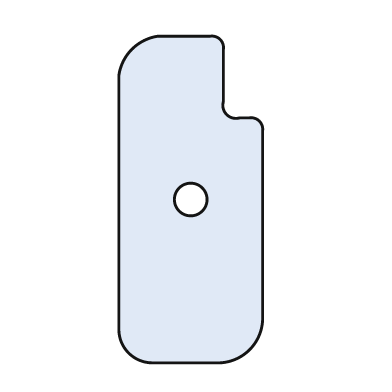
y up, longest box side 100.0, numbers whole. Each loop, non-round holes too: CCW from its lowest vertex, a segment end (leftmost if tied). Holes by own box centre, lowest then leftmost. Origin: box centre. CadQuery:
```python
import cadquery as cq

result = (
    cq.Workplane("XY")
    .moveTo(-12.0, -50.0)
    .lineTo(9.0, -50.0)
    .threePointArc((18.0, -46.0), (22.0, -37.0))
    .lineTo(22.0, 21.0)
    .threePointArc((21.0, 24.0), (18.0, 25.0))
    .lineTo(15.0, 25.0)
    .threePointArc((11.0, 26.0), (10.0, 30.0))
    .lineTo(10.0, 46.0)
    .threePointArc((9.0, 49.0), (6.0, 50.0))
    .lineTo(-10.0, 50.0)
    .threePointArc((-18.0, 46.0), (-22.0, 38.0))
    .lineTo(-22.0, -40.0)
    .threePointArc((-19.0, -47.0), (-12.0, -50.0))
    .close()
    .moveTo(0.0, 0.0)
    .circle(5.0)
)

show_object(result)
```